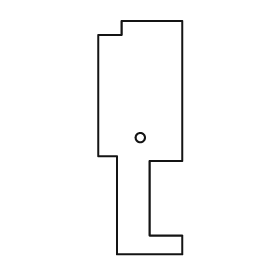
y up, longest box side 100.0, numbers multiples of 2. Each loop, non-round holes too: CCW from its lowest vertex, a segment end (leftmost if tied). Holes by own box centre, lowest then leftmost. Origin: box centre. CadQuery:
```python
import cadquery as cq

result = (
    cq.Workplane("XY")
    .moveTo(-10.0, -50.0)
    .lineTo(18.0, -50.0)
    .lineTo(18.0, -42.0)
    .lineTo(4.0, -42.0)
    .lineTo(4.0, -10.0)
    .lineTo(18.0, -10.0)
    .lineTo(18.0, 50.0)
    .lineTo(-8.0, 50.0)
    .lineTo(-8.0, 44.0)
    .lineTo(-18.0, 44.0)
    .lineTo(-18.0, -8.0)
    .lineTo(-10.0, -8.0)
    .close()
    .moveTo(0.0, 0.0)
    .circle(2.0)
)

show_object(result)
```